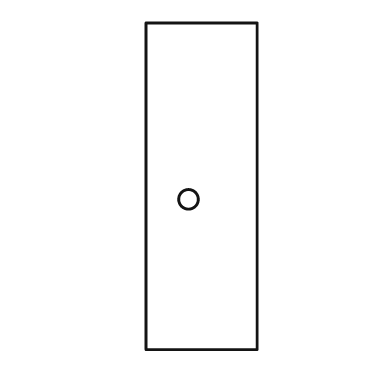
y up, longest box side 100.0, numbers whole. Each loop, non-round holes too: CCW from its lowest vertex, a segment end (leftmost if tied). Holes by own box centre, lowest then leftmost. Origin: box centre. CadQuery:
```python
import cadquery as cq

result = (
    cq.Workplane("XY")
    .moveTo(-17.0, -50.0)
    .lineTo(17.0, -50.0)
    .lineTo(17.0, 50.0)
    .lineTo(-17.0, 50.0)
    .close()
    .moveTo(-4.0, -4.0)
    .circle(3.0)
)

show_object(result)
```